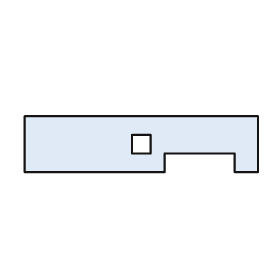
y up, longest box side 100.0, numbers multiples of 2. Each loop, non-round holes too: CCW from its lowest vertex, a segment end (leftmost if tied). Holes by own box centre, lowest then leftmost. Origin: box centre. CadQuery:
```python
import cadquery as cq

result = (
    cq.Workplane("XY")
    .moveTo(-50.0, -12.0)
    .lineTo(10.0, -12.0)
    .lineTo(10.0, -4.0)
    .lineTo(40.0, -4.0)
    .lineTo(40.0, -12.0)
    .lineTo(50.0, -12.0)
    .lineTo(50.0, 12.0)
    .lineTo(-50.0, 12.0)
    .close()
    .moveTo(-4.0, -4.0)
    .lineTo(4.0, -4.0)
    .lineTo(4.0, 4.0)
    .lineTo(-4.0, 4.0)
    .close()
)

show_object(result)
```